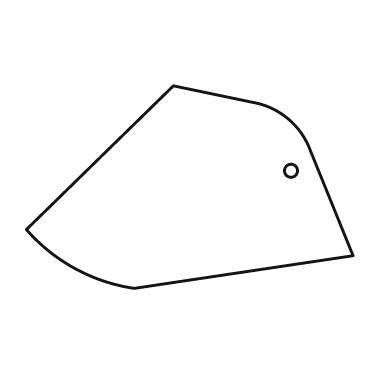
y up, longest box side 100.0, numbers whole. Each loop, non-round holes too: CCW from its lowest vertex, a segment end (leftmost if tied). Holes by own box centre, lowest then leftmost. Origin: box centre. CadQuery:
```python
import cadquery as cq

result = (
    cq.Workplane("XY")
    .moveTo(-17.0, -31.0)
    .lineTo(50.0, -21.0)
    .lineTo(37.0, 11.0)
    .threePointArc((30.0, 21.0), (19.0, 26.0))
    .lineTo(-5.0, 31.0)
    .lineTo(-50.0, -13.0)
    .threePointArc((-35.0, -25.0), (-17.0, -31.0))
    .close()
    .moveTo(31.0, 5.0)
    .circle(2.0)
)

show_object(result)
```